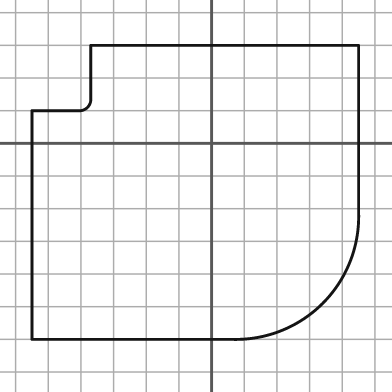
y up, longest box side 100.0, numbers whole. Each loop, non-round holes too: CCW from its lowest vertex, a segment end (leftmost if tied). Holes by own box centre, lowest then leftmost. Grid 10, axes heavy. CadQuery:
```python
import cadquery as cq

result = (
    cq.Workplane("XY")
    .moveTo(-55.0, -60.0)
    .lineTo(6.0, -60.0)
    .threePointArc((34.0, -49.0), (45.0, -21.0))
    .lineTo(45.0, 30.0)
    .lineTo(-37.0, 30.0)
    .lineTo(-37.0, 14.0)
    .threePointArc((-38.0, 11.0), (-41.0, 10.0))
    .lineTo(-55.0, 10.0)
    .close()
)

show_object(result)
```